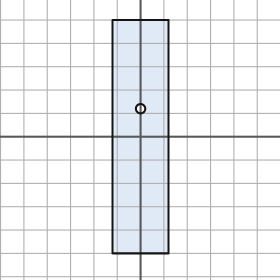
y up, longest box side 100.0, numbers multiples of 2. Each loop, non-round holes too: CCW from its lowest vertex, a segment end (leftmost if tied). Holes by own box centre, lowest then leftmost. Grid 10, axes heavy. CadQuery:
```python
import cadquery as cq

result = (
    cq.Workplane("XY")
    .moveTo(-12.0, -50.0)
    .lineTo(12.0, -50.0)
    .lineTo(12.0, 50.0)
    .lineTo(-12.0, 50.0)
    .close()
    .moveTo(0.0, 12.0)
    .circle(2.0)
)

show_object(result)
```